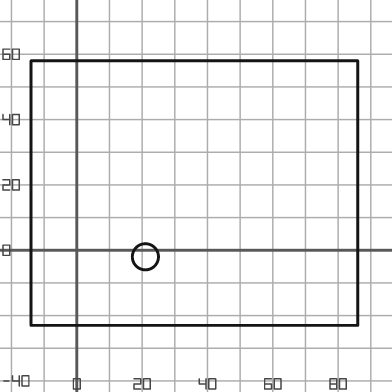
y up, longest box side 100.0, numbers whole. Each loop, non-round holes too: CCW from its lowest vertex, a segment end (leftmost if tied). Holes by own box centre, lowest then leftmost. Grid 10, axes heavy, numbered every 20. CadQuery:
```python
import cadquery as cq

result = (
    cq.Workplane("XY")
    .moveTo(-14.0, -23.0)
    .lineTo(86.0, -23.0)
    .lineTo(86.0, 58.0)
    .lineTo(-14.0, 58.0)
    .close()
    .moveTo(21.0, -2.0)
    .circle(4.0)
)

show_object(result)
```